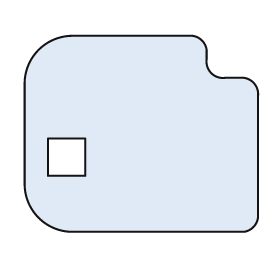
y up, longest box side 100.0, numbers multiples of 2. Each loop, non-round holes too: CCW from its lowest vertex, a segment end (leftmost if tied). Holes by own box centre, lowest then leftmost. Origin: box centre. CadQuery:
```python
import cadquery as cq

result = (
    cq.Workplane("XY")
    .moveTo(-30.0, -42.0)
    .lineTo(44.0, -42.0)
    .threePointArc((48.0, -40.0), (50.0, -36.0))
    .lineTo(50.0, 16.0)
    .threePointArc((48.0, 22.0), (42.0, 24.0))
    .lineTo(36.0, 24.0)
    .threePointArc((30.0, 26.0), (28.0, 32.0))
    .lineTo(28.0, 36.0)
    .threePointArc((26.0, 40.0), (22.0, 42.0))
    .lineTo(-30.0, 42.0)
    .threePointArc((-44.0, 36.0), (-50.0, 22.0))
    .lineTo(-50.0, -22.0)
    .threePointArc((-44.0, -36.0), (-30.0, -42.0))
    .close()
    .moveTo(-40.0, -18.0)
    .lineTo(-24.0, -18.0)
    .lineTo(-24.0, -2.0)
    .lineTo(-40.0, -2.0)
    .close()
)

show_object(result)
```